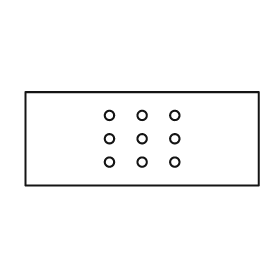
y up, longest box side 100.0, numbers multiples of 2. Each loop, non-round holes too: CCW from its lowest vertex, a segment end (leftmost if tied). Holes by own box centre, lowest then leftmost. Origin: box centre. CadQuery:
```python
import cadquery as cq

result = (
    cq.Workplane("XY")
    .moveTo(-50.0, -20.0)
    .lineTo(50.0, -20.0)
    .lineTo(50.0, 20.0)
    .lineTo(-50.0, 20.0)
    .close()
    .moveTo(-14.0, -10.0)
    .circle(2.0)
    .moveTo(0.0, -10.0)
    .circle(2.0)
    .moveTo(14.0, -10.0)
    .circle(2.0)
    .moveTo(-14.0, 0.0)
    .circle(2.0)
    .moveTo(0.0, 0.0)
    .circle(2.0)
    .moveTo(14.0, 0.0)
    .circle(2.0)
    .moveTo(-14.0, 10.0)
    .circle(2.0)
    .moveTo(0.0, 10.0)
    .circle(2.0)
    .moveTo(14.0, 10.0)
    .circle(2.0)
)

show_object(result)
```